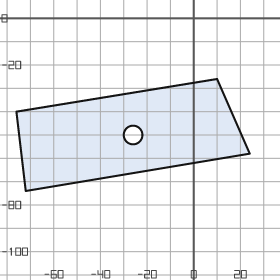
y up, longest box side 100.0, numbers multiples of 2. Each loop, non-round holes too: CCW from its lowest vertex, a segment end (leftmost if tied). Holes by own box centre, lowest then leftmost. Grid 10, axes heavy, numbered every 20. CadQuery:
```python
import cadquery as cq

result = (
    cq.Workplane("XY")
    .moveTo(-72.0, -74.0)
    .lineTo(24.0, -58.0)
    .lineTo(10.0, -26.0)
    .lineTo(-76.0, -40.0)
    .close()
    .moveTo(-26.0, -50.0)
    .circle(4.0)
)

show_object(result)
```